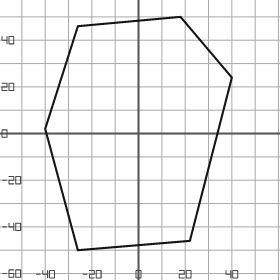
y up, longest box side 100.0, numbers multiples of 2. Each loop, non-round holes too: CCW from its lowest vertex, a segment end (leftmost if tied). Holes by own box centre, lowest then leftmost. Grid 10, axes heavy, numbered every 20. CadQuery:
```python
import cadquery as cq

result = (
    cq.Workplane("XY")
    .moveTo(-26.0, -50.0)
    .lineTo(22.0, -46.0)
    .lineTo(40.0, 24.0)
    .lineTo(18.0, 50.0)
    .lineTo(-26.0, 46.0)
    .lineTo(-40.0, 2.0)
    .close()
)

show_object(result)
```